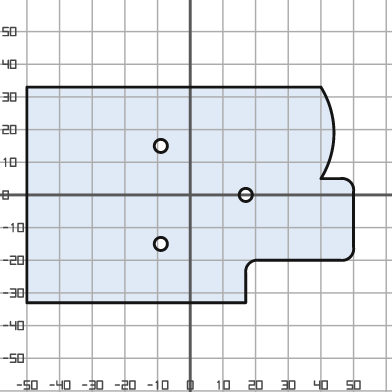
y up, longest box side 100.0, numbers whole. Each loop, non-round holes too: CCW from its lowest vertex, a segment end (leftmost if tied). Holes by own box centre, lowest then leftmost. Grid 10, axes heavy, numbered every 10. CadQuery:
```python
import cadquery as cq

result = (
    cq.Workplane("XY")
    .moveTo(-50.0, -33.0)
    .lineTo(17.0, -33.0)
    .lineTo(17.0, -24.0)
    .threePointArc((18.0, -21.0), (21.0, -20.0))
    .lineTo(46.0, -20.0)
    .threePointArc((49.0, -19.0), (50.0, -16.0))
    .lineTo(50.0, 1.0)
    .threePointArc((49.0, 4.0), (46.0, 5.0))
    .lineTo(40.0, 5.0)
    .threePointArc((44.0, 19.0), (40.0, 33.0))
    .lineTo(-50.0, 33.0)
    .close()
    .moveTo(-9.0, -15.0)
    .circle(2.0)
    .moveTo(17.0, 0.0)
    .circle(2.0)
    .moveTo(-9.0, 15.0)
    .circle(2.0)
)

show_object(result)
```